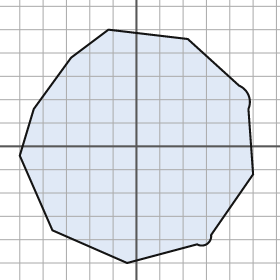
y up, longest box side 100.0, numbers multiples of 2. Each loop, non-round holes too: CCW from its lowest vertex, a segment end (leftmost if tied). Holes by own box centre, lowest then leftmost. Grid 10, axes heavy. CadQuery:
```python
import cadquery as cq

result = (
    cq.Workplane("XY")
    .moveTo(-4.0, -50.0)
    .lineTo(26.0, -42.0)
    .threePointArc((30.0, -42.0), (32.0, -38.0))
    .lineTo(50.0, -12.0)
    .lineTo(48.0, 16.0)
    .threePointArc((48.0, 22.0), (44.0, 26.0))
    .lineTo(22.0, 46.0)
    .lineTo(-12.0, 50.0)
    .lineTo(-28.0, 38.0)
    .lineTo(-44.0, 16.0)
    .lineTo(-50.0, -4.0)
    .lineTo(-36.0, -36.0)
    .close()
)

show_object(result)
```